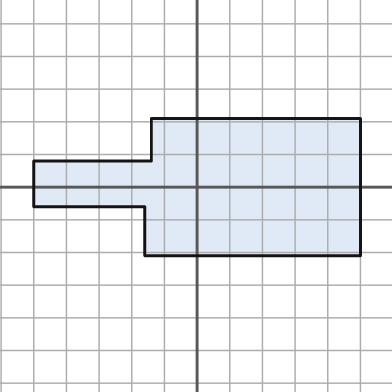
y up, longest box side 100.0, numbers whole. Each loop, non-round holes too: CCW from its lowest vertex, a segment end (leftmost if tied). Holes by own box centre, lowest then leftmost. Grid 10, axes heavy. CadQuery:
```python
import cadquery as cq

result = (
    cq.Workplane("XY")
    .moveTo(-16.0, -21.0)
    .lineTo(50.0, -21.0)
    .lineTo(50.0, 21.0)
    .lineTo(-14.0, 21.0)
    .lineTo(-14.0, 8.0)
    .lineTo(-50.0, 8.0)
    .lineTo(-50.0, -6.0)
    .lineTo(-16.0, -6.0)
    .close()
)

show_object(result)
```